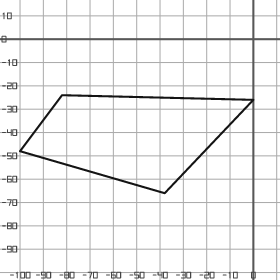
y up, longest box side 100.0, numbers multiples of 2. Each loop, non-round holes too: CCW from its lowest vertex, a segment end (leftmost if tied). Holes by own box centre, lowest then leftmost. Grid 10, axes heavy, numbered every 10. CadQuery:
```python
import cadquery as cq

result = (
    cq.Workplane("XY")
    .moveTo(-38.0, -66.0)
    .lineTo(0.0, -26.0)
    .lineTo(-82.0, -24.0)
    .lineTo(-100.0, -48.0)
    .close()
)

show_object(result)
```